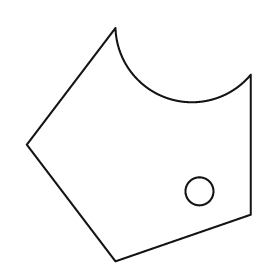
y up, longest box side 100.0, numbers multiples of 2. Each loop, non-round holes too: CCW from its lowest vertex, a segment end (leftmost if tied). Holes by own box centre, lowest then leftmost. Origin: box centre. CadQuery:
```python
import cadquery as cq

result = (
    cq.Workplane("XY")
    .moveTo(-10.0, -50.0)
    .lineTo(48.0, -30.0)
    .lineTo(48.0, 30.0)
    .threePointArc((12.0, 20.0), (-10.0, 50.0))
    .lineTo(-48.0, 0.0)
    .close()
    .moveTo(26.0, -20.0)
    .circle(6.0)
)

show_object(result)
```